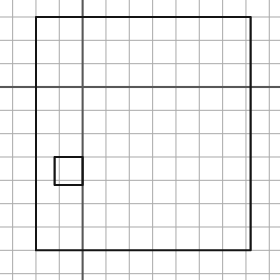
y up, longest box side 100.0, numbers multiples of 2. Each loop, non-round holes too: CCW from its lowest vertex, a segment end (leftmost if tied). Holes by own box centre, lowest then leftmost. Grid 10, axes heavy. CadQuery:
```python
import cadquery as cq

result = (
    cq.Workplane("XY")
    .moveTo(-20.0, -70.0)
    .lineTo(72.0, -70.0)
    .lineTo(72.0, 30.0)
    .lineTo(-20.0, 30.0)
    .close()
    .moveTo(-12.0, -42.0)
    .lineTo(0.0, -42.0)
    .lineTo(0.0, -30.0)
    .lineTo(-12.0, -30.0)
    .close()
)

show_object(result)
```